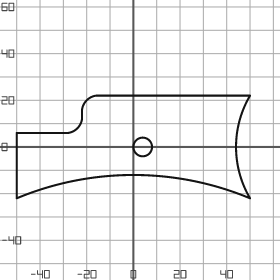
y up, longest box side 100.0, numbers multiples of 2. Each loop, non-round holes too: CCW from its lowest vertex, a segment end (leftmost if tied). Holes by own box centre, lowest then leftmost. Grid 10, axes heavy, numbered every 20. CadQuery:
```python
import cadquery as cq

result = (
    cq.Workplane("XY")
    .moveTo(-50.0, -22.0)
    .threePointArc((0.0, -12.0), (50.0, -22.0))
    .threePointArc((44.0, 0.0), (50.0, 22.0))
    .lineTo(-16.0, 22.0)
    .threePointArc((-20.0, 20.0), (-22.0, 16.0))
    .lineTo(-22.0, 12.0)
    .threePointArc((-24.0, 8.0), (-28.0, 6.0))
    .lineTo(-50.0, 6.0)
    .close()
    .moveTo(4.0, 0.0)
    .circle(4.0)
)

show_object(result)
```